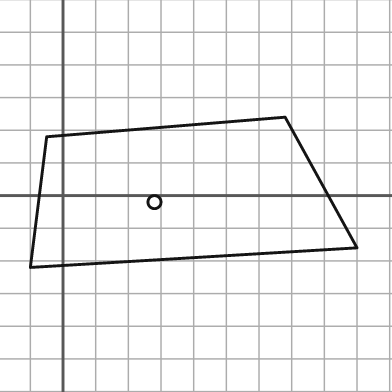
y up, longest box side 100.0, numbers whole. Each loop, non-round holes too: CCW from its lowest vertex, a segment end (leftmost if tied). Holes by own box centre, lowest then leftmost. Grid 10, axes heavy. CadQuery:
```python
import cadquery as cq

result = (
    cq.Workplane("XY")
    .moveTo(-10.0, -22.0)
    .lineTo(90.0, -16.0)
    .lineTo(68.0, 24.0)
    .lineTo(-5.0, 18.0)
    .close()
    .moveTo(28.0, -2.0)
    .circle(2.0)
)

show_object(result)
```